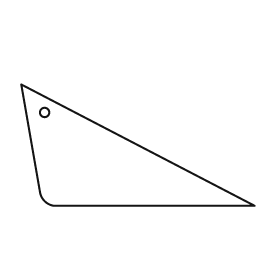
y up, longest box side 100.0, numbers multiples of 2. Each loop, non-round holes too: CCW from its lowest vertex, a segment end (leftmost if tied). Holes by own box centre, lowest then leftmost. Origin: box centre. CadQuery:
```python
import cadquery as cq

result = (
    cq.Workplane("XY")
    .moveTo(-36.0, -26.0)
    .lineTo(50.0, -26.0)
    .lineTo(-50.0, 26.0)
    .lineTo(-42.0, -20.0)
    .threePointArc((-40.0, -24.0), (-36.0, -26.0))
    .close()
    .moveTo(-40.0, 14.0)
    .circle(2.0)
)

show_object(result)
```